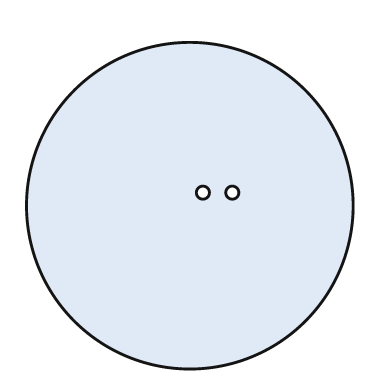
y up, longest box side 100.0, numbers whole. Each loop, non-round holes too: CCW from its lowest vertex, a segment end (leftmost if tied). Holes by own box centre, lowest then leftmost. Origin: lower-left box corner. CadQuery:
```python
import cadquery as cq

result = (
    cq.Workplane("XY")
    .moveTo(50.0, 50.0)
    .circle(50.0)
    .moveTo(54.0, 54.0)
    .circle(2.0)
    .moveTo(63.0, 54.0)
    .circle(2.0)
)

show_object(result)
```